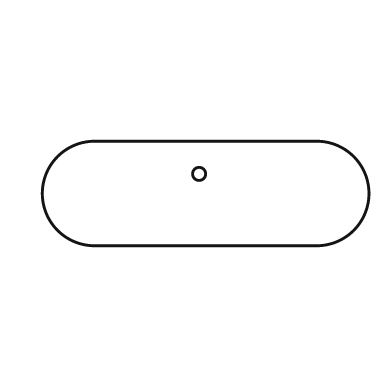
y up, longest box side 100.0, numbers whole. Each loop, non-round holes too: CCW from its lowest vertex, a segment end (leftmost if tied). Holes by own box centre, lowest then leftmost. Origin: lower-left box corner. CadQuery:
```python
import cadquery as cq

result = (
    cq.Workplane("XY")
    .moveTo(16.0, 0.0)
    .lineTo(84.0, 0.0)
    .threePointArc((100.0, 16.0), (84.0, 32.0))
    .lineTo(16.0, 32.0)
    .threePointArc((0.0, 16.0), (16.0, 0.0))
    .close()
    .moveTo(48.0, 22.0)
    .circle(2.0)
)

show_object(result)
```